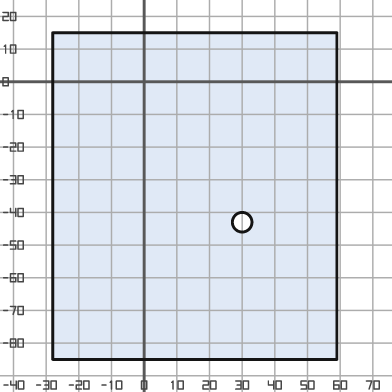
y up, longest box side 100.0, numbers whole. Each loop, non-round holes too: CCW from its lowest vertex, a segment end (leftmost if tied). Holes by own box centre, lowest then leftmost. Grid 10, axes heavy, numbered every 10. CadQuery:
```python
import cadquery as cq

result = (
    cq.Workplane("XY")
    .moveTo(-28.0, -85.0)
    .lineTo(59.0, -85.0)
    .lineTo(59.0, 15.0)
    .lineTo(-28.0, 15.0)
    .close()
    .moveTo(30.0, -43.0)
    .circle(3.0)
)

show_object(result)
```